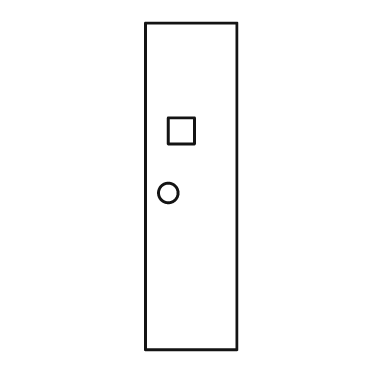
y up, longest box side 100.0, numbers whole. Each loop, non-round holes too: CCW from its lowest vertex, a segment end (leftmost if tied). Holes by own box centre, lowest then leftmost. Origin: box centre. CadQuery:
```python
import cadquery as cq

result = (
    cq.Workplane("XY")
    .moveTo(-14.0, -50.0)
    .lineTo(14.0, -50.0)
    .lineTo(14.0, 50.0)
    .lineTo(-14.0, 50.0)
    .close()
    .moveTo(-7.0, -2.0)
    .circle(3.0)
    .moveTo(-7.0, 13.0)
    .lineTo(1.0, 13.0)
    .lineTo(1.0, 21.0)
    .lineTo(-7.0, 21.0)
    .close()
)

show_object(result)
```